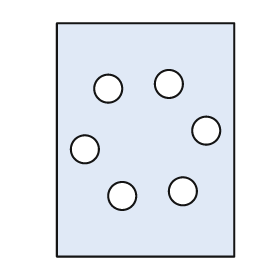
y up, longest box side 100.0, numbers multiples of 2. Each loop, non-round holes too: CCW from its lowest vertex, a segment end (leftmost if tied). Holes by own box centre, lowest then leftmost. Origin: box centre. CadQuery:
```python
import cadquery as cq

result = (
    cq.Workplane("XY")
    .moveTo(-38.0, -50.0)
    .lineTo(38.0, -50.0)
    .lineTo(38.0, 50.0)
    .lineTo(-38.0, 50.0)
    .close()
    .moveTo(-10.0, -24.0)
    .circle(6.0)
    .moveTo(16.0, -22.0)
    .circle(6.0)
    .moveTo(-26.0, -4.0)
    .circle(6.0)
    .moveTo(26.0, 4.0)
    .circle(6.0)
    .moveTo(-16.0, 22.0)
    .circle(6.0)
    .moveTo(10.0, 24.0)
    .circle(6.0)
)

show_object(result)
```